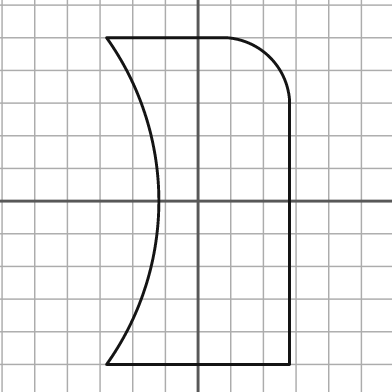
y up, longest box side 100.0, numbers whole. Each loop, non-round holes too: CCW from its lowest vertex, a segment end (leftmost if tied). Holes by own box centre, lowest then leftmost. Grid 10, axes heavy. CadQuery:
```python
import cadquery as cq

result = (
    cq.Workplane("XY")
    .moveTo(-28.0, -50.0)
    .lineTo(28.0, -50.0)
    .lineTo(28.0, 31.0)
    .threePointArc((22.0, 44.0), (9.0, 50.0))
    .lineTo(-28.0, 50.0)
    .threePointArc((-12.0, 0.0), (-28.0, -50.0))
    .close()
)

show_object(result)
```